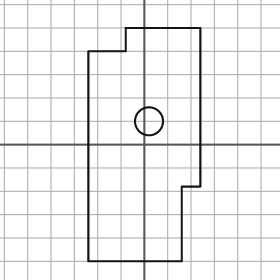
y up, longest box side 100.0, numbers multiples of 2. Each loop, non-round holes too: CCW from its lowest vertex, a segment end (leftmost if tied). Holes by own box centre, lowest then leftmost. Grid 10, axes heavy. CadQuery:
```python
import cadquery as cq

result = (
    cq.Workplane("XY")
    .moveTo(-24.0, -50.0)
    .lineTo(16.0, -50.0)
    .lineTo(16.0, -18.0)
    .lineTo(24.0, -18.0)
    .lineTo(24.0, 50.0)
    .lineTo(-8.0, 50.0)
    .lineTo(-8.0, 40.0)
    .lineTo(-24.0, 40.0)
    .close()
    .moveTo(2.0, 10.0)
    .circle(6.0)
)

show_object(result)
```